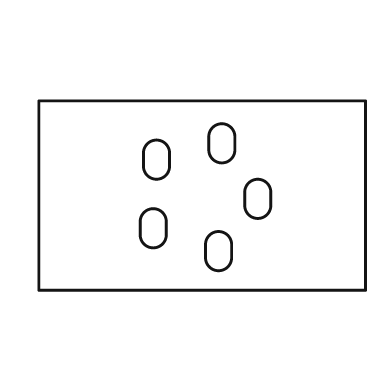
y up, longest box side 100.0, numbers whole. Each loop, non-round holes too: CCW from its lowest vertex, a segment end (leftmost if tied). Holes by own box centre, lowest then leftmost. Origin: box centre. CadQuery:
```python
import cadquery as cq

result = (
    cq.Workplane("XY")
    .moveTo(-50.0, -29.0)
    .lineTo(50.0, -29.0)
    .lineTo(50.0, 29.0)
    .lineTo(-50.0, 29.0)
    .close()
    .moveTo(1.0, -19.0)
    .threePointArc((5.0, -23.0), (9.0, -19.0))
    .lineTo(9.0, -15.0)
    .threePointArc((5.0, -11.0), (1.0, -15.0))
    .close()
    .moveTo(-19.0, -12.0)
    .threePointArc((-15.0, -16.0), (-11.0, -12.0))
    .lineTo(-11.0, -8.0)
    .threePointArc((-15.0, -4.0), (-19.0, -8.0))
    .close()
    .moveTo(13.0, -3.0)
    .threePointArc((17.0, -7.0), (21.0, -3.0))
    .lineTo(21.0, 1.0)
    .threePointArc((17.0, 5.0), (13.0, 1.0))
    .close()
    .moveTo(-18.0, 9.0)
    .threePointArc((-14.0, 5.0), (-10.0, 9.0))
    .lineTo(-10.0, 13.0)
    .threePointArc((-14.0, 17.0), (-18.0, 13.0))
    .close()
    .moveTo(2.0, 14.0)
    .threePointArc((6.0, 10.0), (10.0, 14.0))
    .lineTo(10.0, 18.0)
    .threePointArc((6.0, 22.0), (2.0, 18.0))
    .close()
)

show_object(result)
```